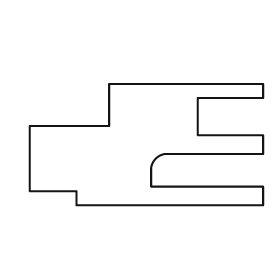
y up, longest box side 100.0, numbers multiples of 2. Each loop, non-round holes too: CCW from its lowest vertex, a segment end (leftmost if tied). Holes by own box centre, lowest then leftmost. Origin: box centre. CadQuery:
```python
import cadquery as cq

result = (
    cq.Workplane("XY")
    .moveTo(-30.0, -26.0)
    .lineTo(50.0, -26.0)
    .lineTo(50.0, -18.0)
    .lineTo(2.0, -18.0)
    .lineTo(2.0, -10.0)
    .threePointArc((4.0, -6.0), (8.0, -4.0))
    .lineTo(50.0, -4.0)
    .lineTo(50.0, 4.0)
    .lineTo(22.0, 4.0)
    .lineTo(22.0, 20.0)
    .lineTo(50.0, 20.0)
    .lineTo(50.0, 26.0)
    .lineTo(-16.0, 26.0)
    .lineTo(-16.0, 8.0)
    .lineTo(-50.0, 8.0)
    .lineTo(-50.0, -20.0)
    .lineTo(-30.0, -20.0)
    .close()
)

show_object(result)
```